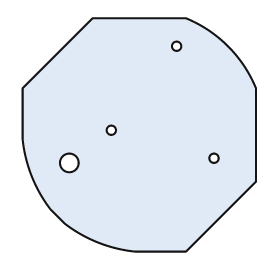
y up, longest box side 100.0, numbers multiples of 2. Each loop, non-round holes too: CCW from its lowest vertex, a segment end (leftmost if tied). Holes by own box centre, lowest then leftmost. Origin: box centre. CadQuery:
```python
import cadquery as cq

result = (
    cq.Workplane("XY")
    .moveTo(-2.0, -50.0)
    .lineTo(20.0, -50.0)
    .lineTo(50.0, -20.0)
    .lineTo(50.0, 20.0)
    .threePointArc((38.0, 38.0), (20.0, 50.0))
    .lineTo(-20.0, 50.0)
    .lineTo(-50.0, 20.0)
    .lineTo(-50.0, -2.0)
    .threePointArc((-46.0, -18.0), (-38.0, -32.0))
    .lineTo(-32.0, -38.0)
    .threePointArc((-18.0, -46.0), (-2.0, -50.0))
    .close()
    .moveTo(-30.0, -12.0)
    .circle(4.0)
    .moveTo(32.0, -10.0)
    .circle(2.0)
    .moveTo(-12.0, 2.0)
    .circle(2.0)
    .moveTo(16.0, 38.0)
    .circle(2.0)
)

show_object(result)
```